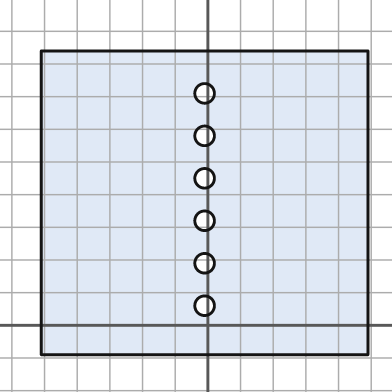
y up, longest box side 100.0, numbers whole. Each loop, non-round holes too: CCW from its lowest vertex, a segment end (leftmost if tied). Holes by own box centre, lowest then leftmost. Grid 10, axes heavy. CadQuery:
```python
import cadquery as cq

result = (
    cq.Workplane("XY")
    .moveTo(-51.0, -9.0)
    .lineTo(49.0, -9.0)
    .lineTo(49.0, 84.0)
    .lineTo(-51.0, 84.0)
    .close()
    .moveTo(-1.0, 6.0)
    .circle(3.0)
    .moveTo(-1.0, 19.0)
    .circle(3.0)
    .moveTo(-1.0, 32.0)
    .circle(3.0)
    .moveTo(-1.0, 45.0)
    .circle(3.0)
    .moveTo(-1.0, 58.0)
    .circle(3.0)
    .moveTo(-1.0, 71.0)
    .circle(3.0)
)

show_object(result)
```